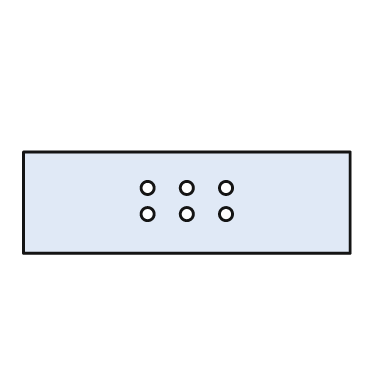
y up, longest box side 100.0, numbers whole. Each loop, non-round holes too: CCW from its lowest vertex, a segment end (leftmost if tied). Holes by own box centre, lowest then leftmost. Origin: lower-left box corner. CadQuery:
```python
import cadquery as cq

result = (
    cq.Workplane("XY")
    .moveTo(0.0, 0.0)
    .lineTo(100.0, 0.0)
    .lineTo(100.0, 31.0)
    .lineTo(0.0, 31.0)
    .close()
    .moveTo(38.0, 12.0)
    .circle(2.0)
    .moveTo(50.0, 12.0)
    .circle(2.0)
    .moveTo(62.0, 12.0)
    .circle(2.0)
    .moveTo(38.0, 20.0)
    .circle(2.0)
    .moveTo(50.0, 20.0)
    .circle(2.0)
    .moveTo(62.0, 20.0)
    .circle(2.0)
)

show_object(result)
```